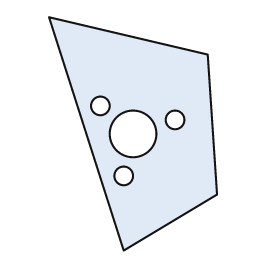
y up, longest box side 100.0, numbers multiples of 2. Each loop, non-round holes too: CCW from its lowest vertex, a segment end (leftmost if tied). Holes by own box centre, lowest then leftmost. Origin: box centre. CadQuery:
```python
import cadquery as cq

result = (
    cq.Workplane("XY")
    .moveTo(-4.0, -50.0)
    .lineTo(36.0, -26.0)
    .lineTo(32.0, 34.0)
    .lineTo(-36.0, 50.0)
    .close()
    .moveTo(-4.0, -18.0)
    .circle(4.0)
    .moveTo(0.0, 0.0)
    .circle(10.0)
    .moveTo(18.0, 6.0)
    .circle(4.0)
    .moveTo(-14.0, 12.0)
    .circle(4.0)
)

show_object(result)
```